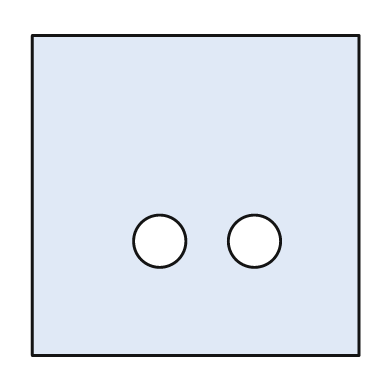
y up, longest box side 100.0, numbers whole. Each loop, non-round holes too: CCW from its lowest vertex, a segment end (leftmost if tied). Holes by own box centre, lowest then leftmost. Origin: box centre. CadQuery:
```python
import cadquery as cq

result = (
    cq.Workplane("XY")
    .moveTo(-50.0, -49.0)
    .lineTo(50.0, -49.0)
    .lineTo(50.0, 49.0)
    .lineTo(-50.0, 49.0)
    .close()
    .moveTo(-11.0, -14.0)
    .circle(8.0)
    .moveTo(18.0, -14.0)
    .circle(8.0)
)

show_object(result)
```